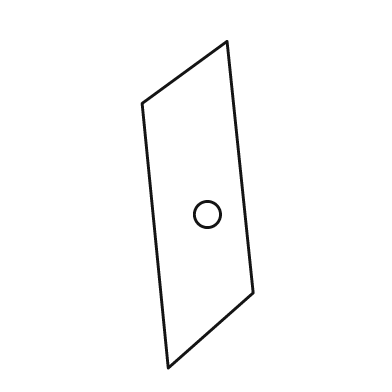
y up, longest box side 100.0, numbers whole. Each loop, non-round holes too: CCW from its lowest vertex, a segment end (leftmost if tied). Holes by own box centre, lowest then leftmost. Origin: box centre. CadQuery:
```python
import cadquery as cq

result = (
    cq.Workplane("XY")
    .moveTo(-9.0, -50.0)
    .lineTo(17.0, -27.0)
    .lineTo(9.0, 50.0)
    .lineTo(-17.0, 31.0)
    .close()
    .moveTo(3.0, -3.0)
    .circle(4.0)
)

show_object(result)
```